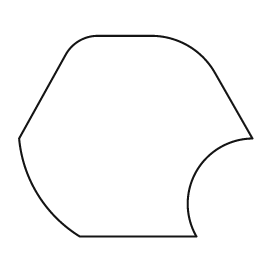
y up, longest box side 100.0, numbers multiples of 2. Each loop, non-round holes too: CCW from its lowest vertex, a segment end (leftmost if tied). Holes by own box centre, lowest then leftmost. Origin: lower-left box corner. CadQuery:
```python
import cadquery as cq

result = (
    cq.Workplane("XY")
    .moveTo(26.0, 0.0)
    .lineTo(76.0, 0.0)
    .threePointArc((76.0, 28.0), (100.0, 42.0))
    .lineTo(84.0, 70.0)
    .threePointArc((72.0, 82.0), (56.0, 86.0))
    .lineTo(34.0, 86.0)
    .threePointArc((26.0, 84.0), (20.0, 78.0))
    .lineTo(0.0, 42.0)
    .threePointArc((8.0, 18.0), (26.0, 0.0))
    .close()
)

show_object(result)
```